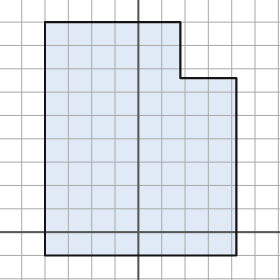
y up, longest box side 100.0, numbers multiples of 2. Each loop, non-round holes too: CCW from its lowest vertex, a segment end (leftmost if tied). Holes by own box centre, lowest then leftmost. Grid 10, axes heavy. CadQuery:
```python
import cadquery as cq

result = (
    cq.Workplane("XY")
    .moveTo(-40.0, -10.0)
    .lineTo(42.0, -10.0)
    .lineTo(42.0, 66.0)
    .lineTo(18.0, 66.0)
    .lineTo(18.0, 90.0)
    .lineTo(-40.0, 90.0)
    .close()
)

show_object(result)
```